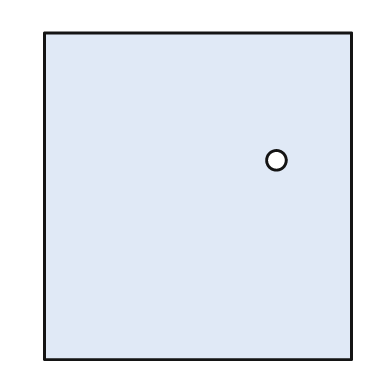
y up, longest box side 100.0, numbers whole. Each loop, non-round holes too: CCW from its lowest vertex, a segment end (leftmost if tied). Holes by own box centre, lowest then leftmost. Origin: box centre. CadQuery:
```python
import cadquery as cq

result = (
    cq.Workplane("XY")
    .moveTo(-47.0, -50.0)
    .lineTo(47.0, -50.0)
    .lineTo(47.0, 50.0)
    .lineTo(-47.0, 50.0)
    .close()
    .moveTo(24.0, 11.0)
    .circle(3.0)
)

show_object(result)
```